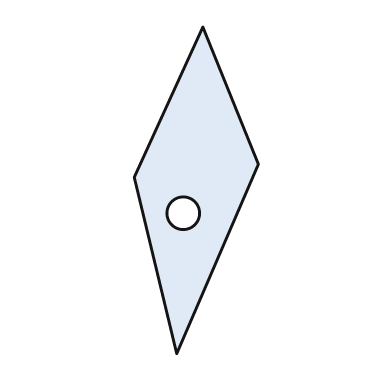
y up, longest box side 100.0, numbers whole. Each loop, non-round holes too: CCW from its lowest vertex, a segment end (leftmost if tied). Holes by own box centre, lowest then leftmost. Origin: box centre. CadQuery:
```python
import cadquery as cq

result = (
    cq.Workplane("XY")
    .moveTo(-6.0, -50.0)
    .lineTo(19.0, 8.0)
    .lineTo(2.0, 50.0)
    .lineTo(-19.0, 4.0)
    .close()
    .moveTo(-4.0, -7.0)
    .circle(5.0)
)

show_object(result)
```